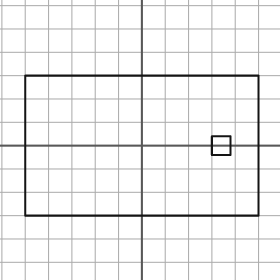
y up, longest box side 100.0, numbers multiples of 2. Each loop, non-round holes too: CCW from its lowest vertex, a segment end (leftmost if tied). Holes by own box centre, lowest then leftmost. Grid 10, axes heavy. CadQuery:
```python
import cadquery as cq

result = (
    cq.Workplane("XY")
    .moveTo(-50.0, -30.0)
    .lineTo(50.0, -30.0)
    .lineTo(50.0, 30.0)
    .lineTo(-50.0, 30.0)
    .close()
    .moveTo(30.0, -4.0)
    .lineTo(38.0, -4.0)
    .lineTo(38.0, 4.0)
    .lineTo(30.0, 4.0)
    .close()
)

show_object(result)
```